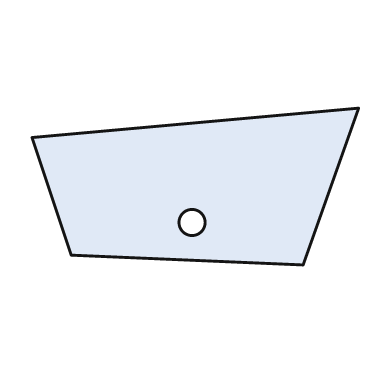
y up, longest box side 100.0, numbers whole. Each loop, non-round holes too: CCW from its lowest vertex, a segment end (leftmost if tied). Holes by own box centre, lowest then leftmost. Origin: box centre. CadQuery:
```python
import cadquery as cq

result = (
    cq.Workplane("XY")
    .moveTo(33.0, -24.0)
    .lineTo(50.0, 24.0)
    .lineTo(-50.0, 15.0)
    .lineTo(-38.0, -21.0)
    .close()
    .moveTo(-1.0, -11.0)
    .circle(4.0)
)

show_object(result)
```